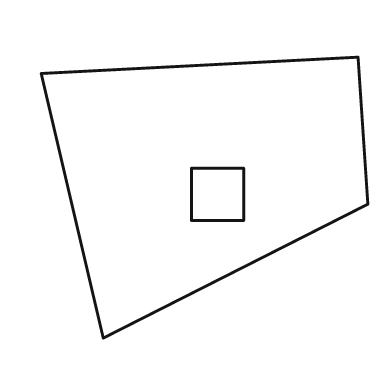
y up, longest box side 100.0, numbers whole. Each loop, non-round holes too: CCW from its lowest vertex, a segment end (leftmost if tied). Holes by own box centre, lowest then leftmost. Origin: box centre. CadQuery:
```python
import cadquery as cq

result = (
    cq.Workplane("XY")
    .moveTo(-31.0, -43.0)
    .lineTo(50.0, -2.0)
    .lineTo(47.0, 43.0)
    .lineTo(-50.0, 38.0)
    .close()
    .moveTo(-4.0, -7.0)
    .lineTo(12.0, -7.0)
    .lineTo(12.0, 9.0)
    .lineTo(-4.0, 9.0)
    .close()
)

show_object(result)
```